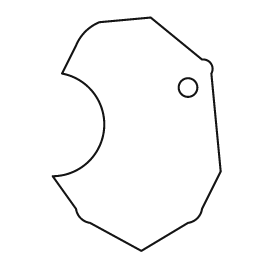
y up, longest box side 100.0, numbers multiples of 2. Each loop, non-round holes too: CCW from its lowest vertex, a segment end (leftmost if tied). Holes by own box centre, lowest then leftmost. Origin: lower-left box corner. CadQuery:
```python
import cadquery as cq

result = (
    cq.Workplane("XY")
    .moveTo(38.0, 0.0)
    .lineTo(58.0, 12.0)
    .threePointArc((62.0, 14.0), (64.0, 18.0))
    .lineTo(72.0, 34.0)
    .lineTo(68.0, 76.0)
    .threePointArc((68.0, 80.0), (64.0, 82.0))
    .lineTo(42.0, 100.0)
    .lineTo(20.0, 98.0)
    .threePointArc((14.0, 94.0), (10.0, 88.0))
    .lineTo(4.0, 76.0)
    .threePointArc((22.0, 52.0), (0.0, 32.0))
    .lineTo(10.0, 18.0)
    .threePointArc((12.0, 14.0), (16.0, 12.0))
    .close()
    .moveTo(58.0, 70.0)
    .circle(4.0)
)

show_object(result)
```